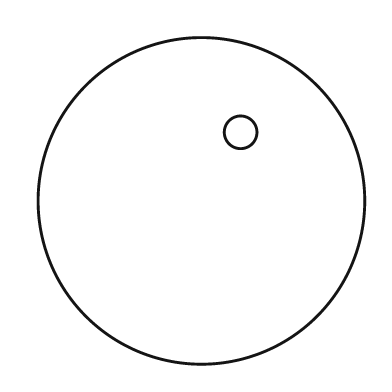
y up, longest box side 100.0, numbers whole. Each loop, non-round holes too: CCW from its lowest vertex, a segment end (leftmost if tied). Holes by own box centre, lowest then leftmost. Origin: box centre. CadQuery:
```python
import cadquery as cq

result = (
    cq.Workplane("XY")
    .moveTo(0.0, 0.0)
    .circle(50.0)
    .moveTo(12.0, 21.0)
    .circle(5.0)
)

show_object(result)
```